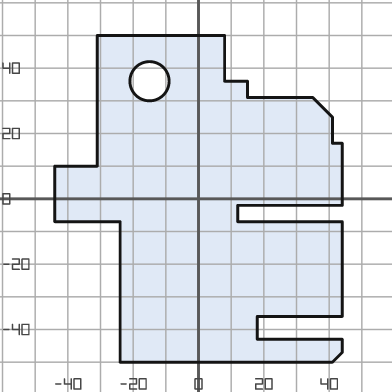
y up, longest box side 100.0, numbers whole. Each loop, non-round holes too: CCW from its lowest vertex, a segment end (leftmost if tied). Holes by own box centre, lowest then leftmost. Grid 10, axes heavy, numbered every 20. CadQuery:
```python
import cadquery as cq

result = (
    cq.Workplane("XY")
    .moveTo(-24.0, -50.0)
    .lineTo(41.0, -50.0)
    .lineTo(44.0, -47.0)
    .lineTo(44.0, -43.0)
    .lineTo(18.0, -43.0)
    .lineTo(18.0, -36.0)
    .lineTo(44.0, -36.0)
    .lineTo(44.0, -7.0)
    .lineTo(12.0, -7.0)
    .lineTo(12.0, -2.0)
    .lineTo(44.0, -2.0)
    .lineTo(44.0, 17.0)
    .lineTo(41.0, 17.0)
    .lineTo(41.0, 25.0)
    .lineTo(35.0, 31.0)
    .lineTo(15.0, 31.0)
    .lineTo(15.0, 36.0)
    .lineTo(8.0, 36.0)
    .lineTo(8.0, 50.0)
    .lineTo(-31.0, 50.0)
    .lineTo(-31.0, 10.0)
    .lineTo(-44.0, 10.0)
    .lineTo(-44.0, -7.0)
    .lineTo(-24.0, -7.0)
    .close()
    .moveTo(-15.0, 36.0)
    .circle(6.0)
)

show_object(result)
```